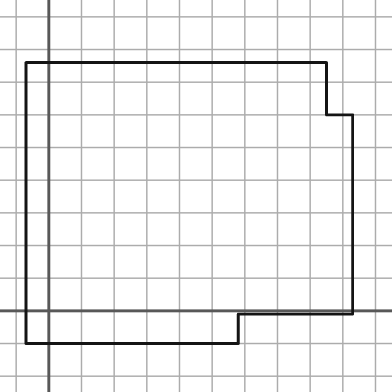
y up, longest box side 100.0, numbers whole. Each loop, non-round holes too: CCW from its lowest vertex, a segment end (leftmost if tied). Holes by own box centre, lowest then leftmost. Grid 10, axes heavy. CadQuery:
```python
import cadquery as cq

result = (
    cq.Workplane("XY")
    .moveTo(-7.0, -10.0)
    .lineTo(58.0, -10.0)
    .lineTo(58.0, -1.0)
    .lineTo(93.0, -1.0)
    .lineTo(93.0, 60.0)
    .lineTo(85.0, 60.0)
    .lineTo(85.0, 76.0)
    .lineTo(-7.0, 76.0)
    .close()
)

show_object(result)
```